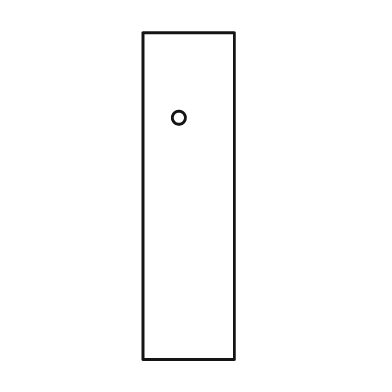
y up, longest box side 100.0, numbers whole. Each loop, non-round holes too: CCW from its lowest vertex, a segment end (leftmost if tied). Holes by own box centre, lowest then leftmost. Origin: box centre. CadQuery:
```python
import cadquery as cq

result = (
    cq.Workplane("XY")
    .moveTo(-14.0, -50.0)
    .lineTo(14.0, -50.0)
    .lineTo(14.0, 50.0)
    .lineTo(-14.0, 50.0)
    .close()
    .moveTo(-3.0, 24.0)
    .circle(2.0)
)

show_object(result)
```